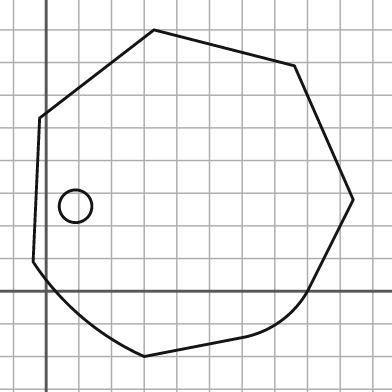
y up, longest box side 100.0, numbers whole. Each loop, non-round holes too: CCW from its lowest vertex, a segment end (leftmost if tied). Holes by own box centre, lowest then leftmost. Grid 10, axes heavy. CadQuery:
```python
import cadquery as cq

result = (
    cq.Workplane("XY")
    .moveTo(30.0, -20.0)
    .lineTo(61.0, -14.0)
    .threePointArc((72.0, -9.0), (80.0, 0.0))
    .lineTo(94.0, 28.0)
    .lineTo(76.0, 69.0)
    .lineTo(33.0, 80.0)
    .lineTo(-2.0, 53.0)
    .lineTo(-4.0, 9.0)
    .threePointArc((11.0, -8.0), (30.0, -20.0))
    .close()
    .moveTo(9.0, 26.0)
    .circle(5.0)
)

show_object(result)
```